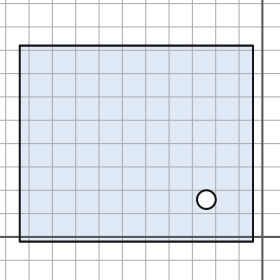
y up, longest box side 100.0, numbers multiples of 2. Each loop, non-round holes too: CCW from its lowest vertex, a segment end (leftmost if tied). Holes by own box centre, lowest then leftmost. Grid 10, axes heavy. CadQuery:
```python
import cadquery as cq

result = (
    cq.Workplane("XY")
    .moveTo(-104.0, -2.0)
    .lineTo(-4.0, -2.0)
    .lineTo(-4.0, 82.0)
    .lineTo(-104.0, 82.0)
    .close()
    .moveTo(-24.0, 16.0)
    .circle(4.0)
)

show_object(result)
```